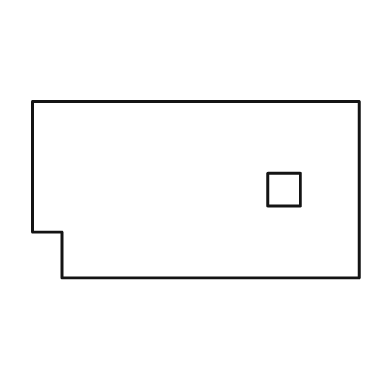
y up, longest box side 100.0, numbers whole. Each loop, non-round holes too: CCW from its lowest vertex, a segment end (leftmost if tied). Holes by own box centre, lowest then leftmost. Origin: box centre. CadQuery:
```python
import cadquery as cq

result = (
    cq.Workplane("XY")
    .moveTo(-41.0, -27.0)
    .lineTo(50.0, -27.0)
    .lineTo(50.0, 27.0)
    .lineTo(-50.0, 27.0)
    .lineTo(-50.0, -13.0)
    .lineTo(-41.0, -13.0)
    .close()
    .moveTo(22.0, -5.0)
    .lineTo(32.0, -5.0)
    .lineTo(32.0, 5.0)
    .lineTo(22.0, 5.0)
    .close()
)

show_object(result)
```